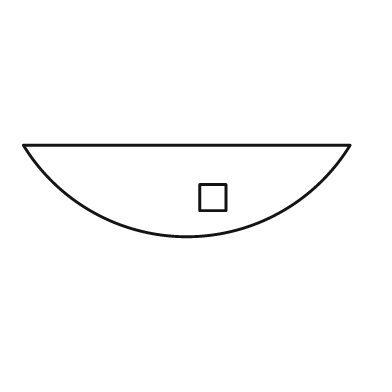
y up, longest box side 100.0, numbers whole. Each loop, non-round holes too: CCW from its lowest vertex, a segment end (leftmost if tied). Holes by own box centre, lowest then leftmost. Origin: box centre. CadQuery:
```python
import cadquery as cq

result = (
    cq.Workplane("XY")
    .moveTo(-50.0, 14.0)
    .threePointArc((0.0, -14.0), (50.0, 14.0))
    .close()
    .moveTo(4.0, -6.0)
    .lineTo(12.0, -6.0)
    .lineTo(12.0, 2.0)
    .lineTo(4.0, 2.0)
    .close()
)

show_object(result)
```